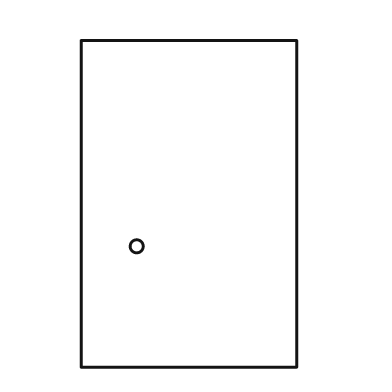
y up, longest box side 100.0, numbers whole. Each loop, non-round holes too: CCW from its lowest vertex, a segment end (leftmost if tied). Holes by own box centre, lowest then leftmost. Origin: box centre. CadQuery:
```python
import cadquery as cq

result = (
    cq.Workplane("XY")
    .moveTo(-33.0, -50.0)
    .lineTo(33.0, -50.0)
    .lineTo(33.0, 50.0)
    .lineTo(-33.0, 50.0)
    .close()
    .moveTo(-16.0, -13.0)
    .circle(2.0)
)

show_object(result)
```